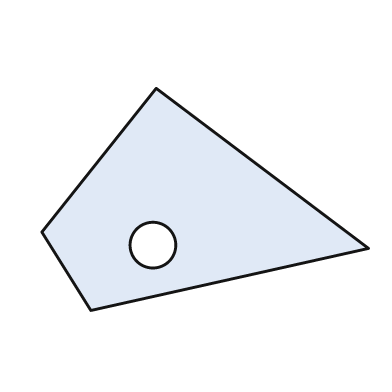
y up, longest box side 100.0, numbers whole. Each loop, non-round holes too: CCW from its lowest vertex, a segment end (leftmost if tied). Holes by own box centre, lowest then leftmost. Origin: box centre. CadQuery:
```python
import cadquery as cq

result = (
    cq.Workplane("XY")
    .moveTo(-35.0, -34.0)
    .lineTo(50.0, -15.0)
    .lineTo(-15.0, 34.0)
    .lineTo(-50.0, -10.0)
    .close()
    .moveTo(-16.0, -14.0)
    .circle(7.0)
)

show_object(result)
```